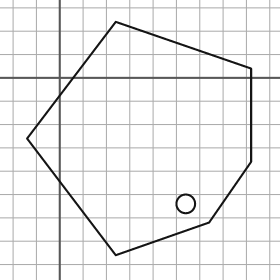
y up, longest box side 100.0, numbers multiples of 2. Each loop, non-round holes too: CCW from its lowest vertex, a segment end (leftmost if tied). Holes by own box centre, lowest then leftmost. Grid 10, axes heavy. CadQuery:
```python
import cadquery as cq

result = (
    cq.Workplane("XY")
    .moveTo(24.0, -76.0)
    .lineTo(64.0, -62.0)
    .lineTo(82.0, -36.0)
    .lineTo(82.0, 4.0)
    .lineTo(24.0, 24.0)
    .lineTo(-14.0, -26.0)
    .close()
    .moveTo(54.0, -54.0)
    .circle(4.0)
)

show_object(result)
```